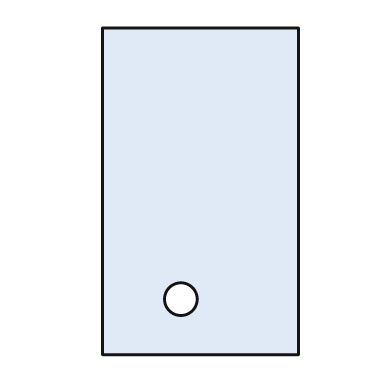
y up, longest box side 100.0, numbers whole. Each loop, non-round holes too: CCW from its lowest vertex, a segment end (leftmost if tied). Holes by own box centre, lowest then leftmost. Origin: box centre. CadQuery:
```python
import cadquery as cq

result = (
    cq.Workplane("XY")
    .moveTo(-30.0, -50.0)
    .lineTo(30.0, -50.0)
    .lineTo(30.0, 50.0)
    .lineTo(-30.0, 50.0)
    .close()
    .moveTo(-6.0, -33.0)
    .circle(5.0)
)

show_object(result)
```